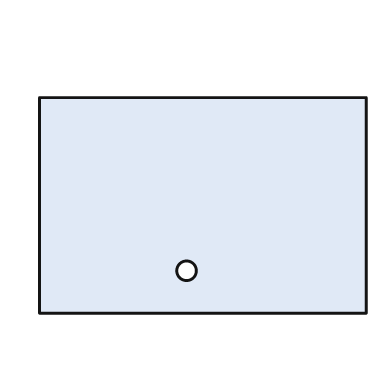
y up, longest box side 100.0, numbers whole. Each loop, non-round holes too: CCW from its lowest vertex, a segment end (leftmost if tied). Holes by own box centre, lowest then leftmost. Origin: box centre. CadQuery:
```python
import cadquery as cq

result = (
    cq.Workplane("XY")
    .moveTo(-50.0, -33.0)
    .lineTo(50.0, -33.0)
    .lineTo(50.0, 33.0)
    .lineTo(-50.0, 33.0)
    .close()
    .moveTo(-5.0, -20.0)
    .circle(3.0)
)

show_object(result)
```